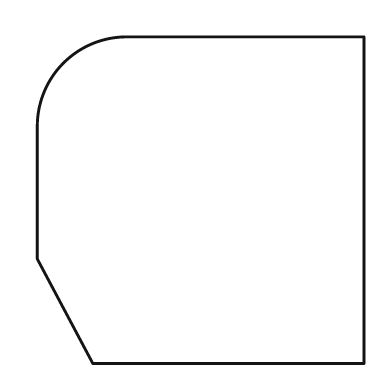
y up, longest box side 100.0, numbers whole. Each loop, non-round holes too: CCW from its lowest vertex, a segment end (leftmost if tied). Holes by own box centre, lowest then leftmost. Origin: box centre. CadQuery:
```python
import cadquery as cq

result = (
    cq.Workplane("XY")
    .moveTo(-33.0, -50.0)
    .lineTo(50.0, -50.0)
    .lineTo(50.0, 50.0)
    .lineTo(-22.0, 50.0)
    .threePointArc((-42.0, 42.0), (-50.0, 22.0))
    .lineTo(-50.0, -18.0)
    .close()
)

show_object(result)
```